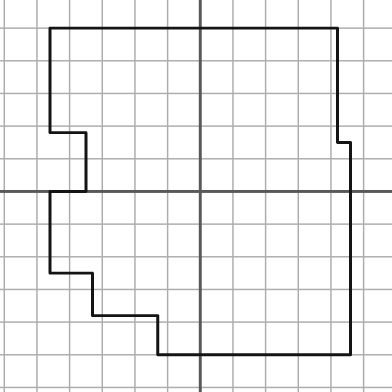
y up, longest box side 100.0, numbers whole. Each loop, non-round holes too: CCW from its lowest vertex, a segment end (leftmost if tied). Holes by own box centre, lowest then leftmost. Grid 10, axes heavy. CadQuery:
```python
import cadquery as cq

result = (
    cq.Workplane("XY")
    .moveTo(-13.0, -50.0)
    .lineTo(46.0, -50.0)
    .lineTo(46.0, 15.0)
    .lineTo(42.0, 15.0)
    .lineTo(42.0, 50.0)
    .lineTo(-46.0, 50.0)
    .lineTo(-46.0, 18.0)
    .lineTo(-35.0, 18.0)
    .lineTo(-35.0, 0.0)
    .lineTo(-46.0, 0.0)
    .lineTo(-46.0, -25.0)
    .lineTo(-33.0, -25.0)
    .lineTo(-33.0, -38.0)
    .lineTo(-13.0, -38.0)
    .close()
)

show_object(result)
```